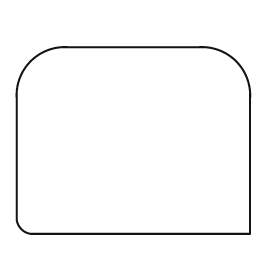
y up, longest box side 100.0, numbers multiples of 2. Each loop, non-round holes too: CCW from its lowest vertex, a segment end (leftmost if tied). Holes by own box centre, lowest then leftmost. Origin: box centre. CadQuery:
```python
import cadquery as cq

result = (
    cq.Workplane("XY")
    .moveTo(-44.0, -40.0)
    .lineTo(50.0, -40.0)
    .lineTo(50.0, 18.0)
    .threePointArc((44.0, 34.0), (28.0, 40.0))
    .lineTo(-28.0, 40.0)
    .threePointArc((-44.0, 34.0), (-50.0, 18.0))
    .lineTo(-50.0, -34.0)
    .threePointArc((-48.0, -38.0), (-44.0, -40.0))
    .close()
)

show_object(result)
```